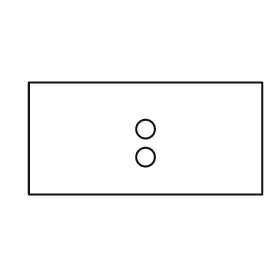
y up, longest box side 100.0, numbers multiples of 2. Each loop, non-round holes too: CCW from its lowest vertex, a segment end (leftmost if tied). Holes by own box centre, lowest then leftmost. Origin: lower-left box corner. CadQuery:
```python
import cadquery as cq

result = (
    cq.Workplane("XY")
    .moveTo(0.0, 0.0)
    .lineTo(100.0, 0.0)
    .lineTo(100.0, 48.0)
    .lineTo(0.0, 48.0)
    .close()
    .moveTo(50.0, 16.0)
    .circle(4.0)
    .moveTo(50.0, 28.0)
    .circle(4.0)
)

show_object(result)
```